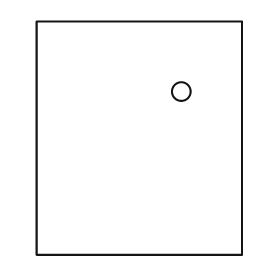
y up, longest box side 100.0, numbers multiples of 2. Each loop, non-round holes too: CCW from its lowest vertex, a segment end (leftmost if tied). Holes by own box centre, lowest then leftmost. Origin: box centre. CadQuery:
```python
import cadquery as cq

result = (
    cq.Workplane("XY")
    .moveTo(-44.0, -50.0)
    .lineTo(44.0, -50.0)
    .lineTo(44.0, 50.0)
    .lineTo(-44.0, 50.0)
    .close()
    .moveTo(18.0, 20.0)
    .circle(4.0)
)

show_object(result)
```